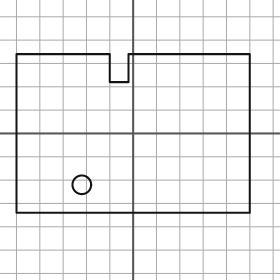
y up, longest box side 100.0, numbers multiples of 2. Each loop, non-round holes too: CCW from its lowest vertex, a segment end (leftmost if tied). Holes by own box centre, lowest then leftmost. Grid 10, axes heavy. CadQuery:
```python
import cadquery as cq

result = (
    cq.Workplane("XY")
    .moveTo(-50.0, -34.0)
    .lineTo(50.0, -34.0)
    .lineTo(50.0, 34.0)
    .lineTo(-2.0, 34.0)
    .lineTo(-2.0, 22.0)
    .lineTo(-10.0, 22.0)
    .lineTo(-10.0, 34.0)
    .lineTo(-50.0, 34.0)
    .close()
    .moveTo(-22.0, -22.0)
    .circle(4.0)
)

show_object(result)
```